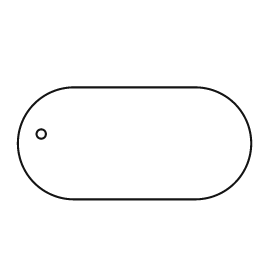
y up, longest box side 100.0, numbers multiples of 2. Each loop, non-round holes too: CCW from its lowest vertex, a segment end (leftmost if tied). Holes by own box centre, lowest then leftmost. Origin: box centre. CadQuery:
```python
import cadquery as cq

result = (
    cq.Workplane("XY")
    .moveTo(-26.0, -24.0)
    .lineTo(26.0, -24.0)
    .threePointArc((50.0, 0.0), (26.0, 24.0))
    .lineTo(-26.0, 24.0)
    .threePointArc((-50.0, 0.0), (-26.0, -24.0))
    .close()
    .moveTo(-40.0, 4.0)
    .circle(2.0)
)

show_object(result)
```